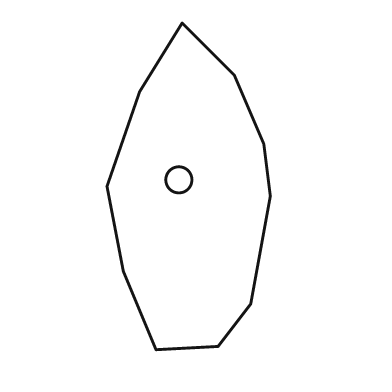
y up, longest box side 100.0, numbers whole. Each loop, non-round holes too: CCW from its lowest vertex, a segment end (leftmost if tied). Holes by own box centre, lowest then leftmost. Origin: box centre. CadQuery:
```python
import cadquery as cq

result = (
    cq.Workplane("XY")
    .moveTo(-10.0, -50.0)
    .lineTo(9.0, -49.0)
    .lineTo(19.0, -36.0)
    .lineTo(25.0, -3.0)
    .lineTo(23.0, 13.0)
    .lineTo(14.0, 34.0)
    .lineTo(-2.0, 50.0)
    .lineTo(-15.0, 29.0)
    .lineTo(-25.0, 0.0)
    .lineTo(-20.0, -26.0)
    .close()
    .moveTo(-3.0, 2.0)
    .circle(4.0)
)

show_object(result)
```